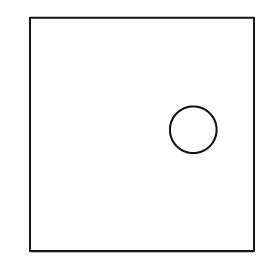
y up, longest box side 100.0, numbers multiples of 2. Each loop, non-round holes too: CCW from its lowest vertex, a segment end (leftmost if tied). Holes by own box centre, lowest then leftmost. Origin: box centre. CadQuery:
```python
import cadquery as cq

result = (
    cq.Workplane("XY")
    .moveTo(-48.0, -50.0)
    .lineTo(48.0, -50.0)
    .lineTo(48.0, 50.0)
    .lineTo(-48.0, 50.0)
    .close()
    .moveTo(22.0, 2.0)
    .circle(10.0)
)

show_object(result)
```